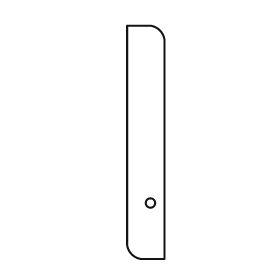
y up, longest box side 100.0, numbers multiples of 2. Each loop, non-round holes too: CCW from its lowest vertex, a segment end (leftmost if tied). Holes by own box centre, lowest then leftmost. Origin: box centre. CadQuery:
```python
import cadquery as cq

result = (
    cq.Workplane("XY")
    .moveTo(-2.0, -50.0)
    .lineTo(8.0, -50.0)
    .lineTo(8.0, 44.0)
    .threePointArc((6.0, 48.0), (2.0, 50.0))
    .lineTo(-8.0, 50.0)
    .lineTo(-8.0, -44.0)
    .threePointArc((-6.0, -48.0), (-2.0, -50.0))
    .close()
    .moveTo(2.0, -26.0)
    .circle(2.0)
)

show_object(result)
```